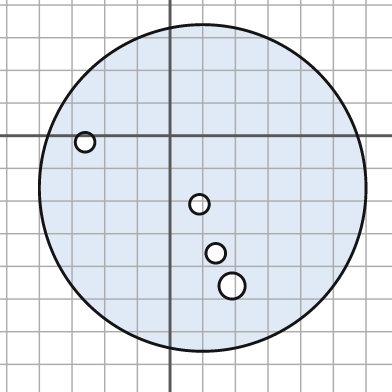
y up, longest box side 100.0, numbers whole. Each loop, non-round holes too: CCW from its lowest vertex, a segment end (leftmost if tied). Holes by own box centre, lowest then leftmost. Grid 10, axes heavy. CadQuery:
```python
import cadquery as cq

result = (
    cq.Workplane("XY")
    .moveTo(10.0, -16.0)
    .circle(50.0)
    .moveTo(19.0, -46.0)
    .circle(4.0)
    .moveTo(14.0, -36.0)
    .circle(3.0)
    .moveTo(9.0, -21.0)
    .circle(3.0)
    .moveTo(-26.0, -2.0)
    .circle(3.0)
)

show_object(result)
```